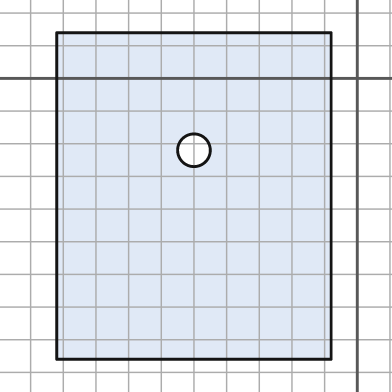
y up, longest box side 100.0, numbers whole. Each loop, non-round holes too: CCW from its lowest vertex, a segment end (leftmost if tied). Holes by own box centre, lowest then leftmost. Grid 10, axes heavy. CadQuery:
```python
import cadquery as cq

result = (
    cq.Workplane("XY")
    .moveTo(-92.0, -86.0)
    .lineTo(-8.0, -86.0)
    .lineTo(-8.0, 14.0)
    .lineTo(-92.0, 14.0)
    .close()
    .moveTo(-50.0, -22.0)
    .circle(5.0)
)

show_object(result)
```